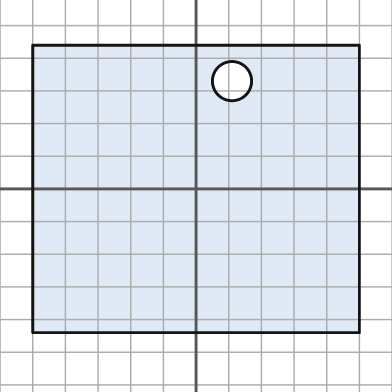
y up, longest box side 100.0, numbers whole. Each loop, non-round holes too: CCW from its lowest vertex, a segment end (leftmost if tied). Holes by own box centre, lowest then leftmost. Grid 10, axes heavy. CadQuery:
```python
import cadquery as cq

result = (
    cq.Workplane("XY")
    .moveTo(-50.0, -44.0)
    .lineTo(50.0, -44.0)
    .lineTo(50.0, 44.0)
    .lineTo(-50.0, 44.0)
    .close()
    .moveTo(11.0, 33.0)
    .circle(6.0)
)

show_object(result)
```